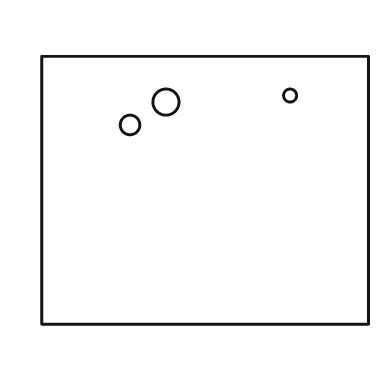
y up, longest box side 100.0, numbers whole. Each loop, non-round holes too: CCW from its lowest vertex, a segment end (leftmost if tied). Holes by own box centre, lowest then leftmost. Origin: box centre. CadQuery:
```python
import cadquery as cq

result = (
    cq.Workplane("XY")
    .moveTo(-50.0, -41.0)
    .lineTo(50.0, -41.0)
    .lineTo(50.0, 41.0)
    .lineTo(-50.0, 41.0)
    .close()
    .moveTo(-23.0, 20.0)
    .circle(3.0)
    .moveTo(-12.0, 27.0)
    .circle(4.0)
    .moveTo(26.0, 29.0)
    .circle(2.0)
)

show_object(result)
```